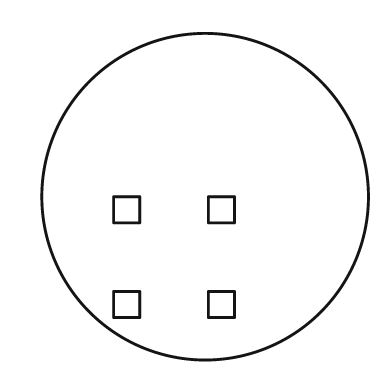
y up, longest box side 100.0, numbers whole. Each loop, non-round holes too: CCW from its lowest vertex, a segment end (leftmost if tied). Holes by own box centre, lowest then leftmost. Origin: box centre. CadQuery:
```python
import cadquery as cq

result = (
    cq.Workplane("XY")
    .moveTo(0.0, 0.0)
    .circle(50.0)
    .moveTo(-28.0, -37.0)
    .lineTo(-20.0, -37.0)
    .lineTo(-20.0, -29.0)
    .lineTo(-28.0, -29.0)
    .close()
    .moveTo(1.0, -37.0)
    .lineTo(9.0, -37.0)
    .lineTo(9.0, -29.0)
    .lineTo(1.0, -29.0)
    .close()
    .moveTo(-28.0, -8.0)
    .lineTo(-20.0, -8.0)
    .lineTo(-20.0, 0.0)
    .lineTo(-28.0, 0.0)
    .close()
    .moveTo(1.0, -8.0)
    .lineTo(9.0, -8.0)
    .lineTo(9.0, 0.0)
    .lineTo(1.0, 0.0)
    .close()
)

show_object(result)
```